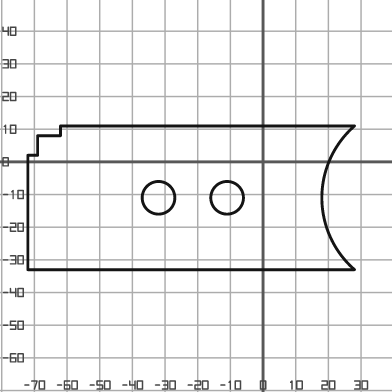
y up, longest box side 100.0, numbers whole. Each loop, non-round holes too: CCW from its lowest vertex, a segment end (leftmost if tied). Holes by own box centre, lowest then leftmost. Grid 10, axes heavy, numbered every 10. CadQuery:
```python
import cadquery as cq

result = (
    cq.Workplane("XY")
    .moveTo(-72.0, -33.0)
    .lineTo(28.0, -33.0)
    .threePointArc((18.0, -11.0), (28.0, 11.0))
    .lineTo(-62.0, 11.0)
    .lineTo(-62.0, 8.0)
    .lineTo(-69.0, 8.0)
    .lineTo(-69.0, 2.0)
    .lineTo(-72.0, 2.0)
    .close()
    .moveTo(-32.0, -11.0)
    .circle(5.0)
    .moveTo(-11.0, -11.0)
    .circle(5.0)
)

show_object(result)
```